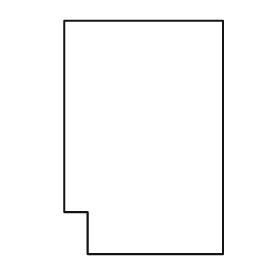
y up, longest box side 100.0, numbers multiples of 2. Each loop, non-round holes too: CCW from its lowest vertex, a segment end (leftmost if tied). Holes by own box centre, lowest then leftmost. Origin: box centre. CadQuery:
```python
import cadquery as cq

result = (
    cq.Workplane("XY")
    .moveTo(-24.0, -50.0)
    .lineTo(34.0, -50.0)
    .lineTo(34.0, 50.0)
    .lineTo(-34.0, 50.0)
    .lineTo(-34.0, -32.0)
    .lineTo(-24.0, -32.0)
    .close()
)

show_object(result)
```